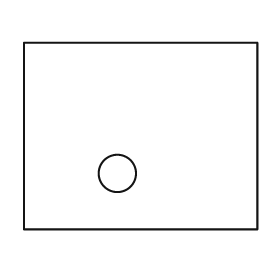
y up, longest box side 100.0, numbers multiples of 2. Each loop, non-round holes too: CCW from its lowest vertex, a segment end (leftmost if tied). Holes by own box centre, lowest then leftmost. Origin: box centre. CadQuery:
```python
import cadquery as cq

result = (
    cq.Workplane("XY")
    .moveTo(-50.0, -40.0)
    .lineTo(50.0, -40.0)
    .lineTo(50.0, 40.0)
    .lineTo(-50.0, 40.0)
    .close()
    .moveTo(-10.0, -16.0)
    .circle(8.0)
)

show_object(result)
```